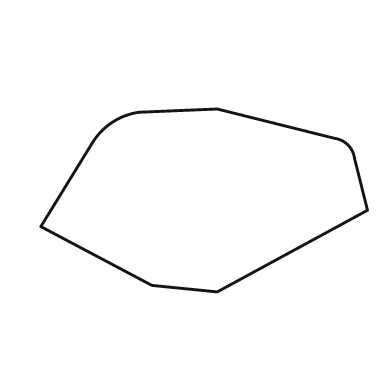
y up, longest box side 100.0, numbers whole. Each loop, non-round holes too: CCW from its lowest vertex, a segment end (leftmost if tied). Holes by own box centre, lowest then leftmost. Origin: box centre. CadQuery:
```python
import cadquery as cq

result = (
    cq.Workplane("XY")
    .moveTo(4.0, -28.0)
    .lineTo(50.0, -3.0)
    .lineTo(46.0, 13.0)
    .threePointArc((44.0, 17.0), (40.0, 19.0))
    .lineTo(4.0, 28.0)
    .lineTo(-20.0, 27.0)
    .threePointArc((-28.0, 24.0), (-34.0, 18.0))
    .lineTo(-50.0, -8.0)
    .lineTo(-16.0, -26.0)
    .close()
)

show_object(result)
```